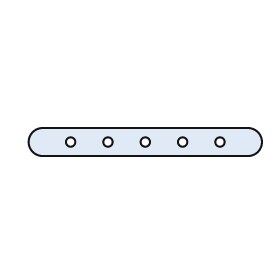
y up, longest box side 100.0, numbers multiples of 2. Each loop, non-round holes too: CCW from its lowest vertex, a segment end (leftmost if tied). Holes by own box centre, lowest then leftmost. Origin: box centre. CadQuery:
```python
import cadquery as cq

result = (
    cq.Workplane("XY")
    .moveTo(-44.0, -6.0)
    .lineTo(44.0, -6.0)
    .threePointArc((50.0, 0.0), (44.0, 6.0))
    .lineTo(-44.0, 6.0)
    .threePointArc((-50.0, 0.0), (-44.0, -6.0))
    .close()
    .moveTo(-32.0, 0.0)
    .circle(2.0)
    .moveTo(-16.0, 0.0)
    .circle(2.0)
    .moveTo(0.0, 0.0)
    .circle(2.0)
    .moveTo(16.0, 0.0)
    .circle(2.0)
    .moveTo(32.0, 0.0)
    .circle(2.0)
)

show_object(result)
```